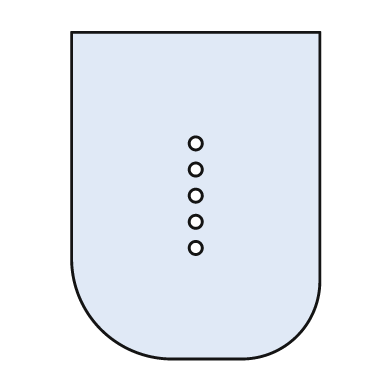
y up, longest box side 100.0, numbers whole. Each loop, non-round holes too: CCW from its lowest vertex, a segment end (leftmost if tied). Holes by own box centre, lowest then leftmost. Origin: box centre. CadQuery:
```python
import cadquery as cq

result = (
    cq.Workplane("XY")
    .moveTo(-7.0, -50.0)
    .lineTo(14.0, -50.0)
    .threePointArc((31.0, -43.0), (38.0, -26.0))
    .lineTo(38.0, 50.0)
    .lineTo(-38.0, 50.0)
    .lineTo(-38.0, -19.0)
    .threePointArc((-29.0, -41.0), (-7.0, -50.0))
    .close()
    .moveTo(0.0, -16.0)
    .circle(2.0)
    .moveTo(0.0, -8.0)
    .circle(2.0)
    .moveTo(0.0, 0.0)
    .circle(2.0)
    .moveTo(0.0, 8.0)
    .circle(2.0)
    .moveTo(0.0, 16.0)
    .circle(2.0)
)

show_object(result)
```